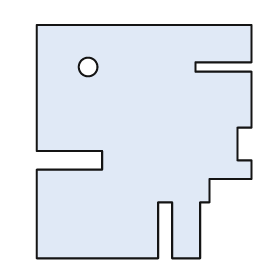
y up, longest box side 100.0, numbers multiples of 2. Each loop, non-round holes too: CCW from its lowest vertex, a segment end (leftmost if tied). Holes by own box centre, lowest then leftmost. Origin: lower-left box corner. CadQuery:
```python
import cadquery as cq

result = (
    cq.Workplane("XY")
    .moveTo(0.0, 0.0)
    .lineTo(52.0, 0.0)
    .lineTo(52.0, 24.0)
    .lineTo(58.0, 24.0)
    .lineTo(58.0, 0.0)
    .lineTo(70.0, 0.0)
    .lineTo(70.0, 24.0)
    .lineTo(74.0, 24.0)
    .lineTo(74.0, 34.0)
    .lineTo(92.0, 34.0)
    .lineTo(92.0, 42.0)
    .lineTo(86.0, 42.0)
    .lineTo(86.0, 56.0)
    .lineTo(92.0, 56.0)
    .lineTo(92.0, 80.0)
    .lineTo(68.0, 80.0)
    .lineTo(68.0, 84.0)
    .lineTo(92.0, 84.0)
    .lineTo(92.0, 100.0)
    .lineTo(0.0, 100.0)
    .lineTo(0.0, 46.0)
    .lineTo(28.0, 46.0)
    .lineTo(28.0, 38.0)
    .lineTo(0.0, 38.0)
    .close()
    .moveTo(22.0, 82.0)
    .circle(4.0)
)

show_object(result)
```